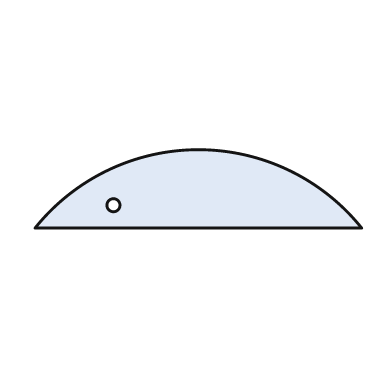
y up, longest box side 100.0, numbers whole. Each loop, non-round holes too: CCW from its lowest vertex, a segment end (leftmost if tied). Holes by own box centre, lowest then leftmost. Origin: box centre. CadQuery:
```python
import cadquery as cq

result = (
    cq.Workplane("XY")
    .moveTo(-50.0, -12.0)
    .lineTo(50.0, -12.0)
    .threePointArc((0.0, 12.0), (-50.0, -12.0))
    .close()
    .moveTo(-26.0, -5.0)
    .circle(2.0)
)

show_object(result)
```